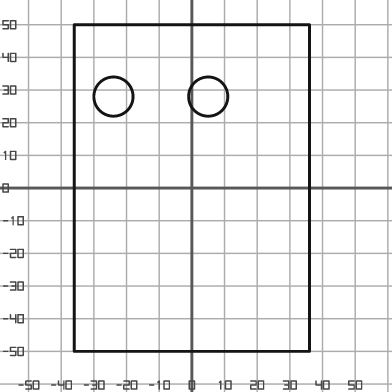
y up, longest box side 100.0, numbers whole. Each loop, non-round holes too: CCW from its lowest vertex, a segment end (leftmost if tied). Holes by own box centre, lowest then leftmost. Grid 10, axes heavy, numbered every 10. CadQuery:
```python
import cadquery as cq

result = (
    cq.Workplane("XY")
    .moveTo(-36.0, -50.0)
    .lineTo(36.0, -50.0)
    .lineTo(36.0, 50.0)
    .lineTo(-36.0, 50.0)
    .close()
    .moveTo(-24.0, 28.0)
    .circle(6.0)
    .moveTo(5.0, 28.0)
    .circle(6.0)
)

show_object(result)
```